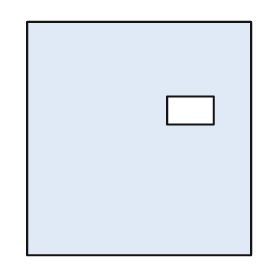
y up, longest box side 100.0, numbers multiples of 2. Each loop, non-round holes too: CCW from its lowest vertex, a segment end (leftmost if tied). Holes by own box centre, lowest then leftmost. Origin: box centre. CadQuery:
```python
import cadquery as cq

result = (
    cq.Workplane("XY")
    .moveTo(-48.0, -50.0)
    .lineTo(48.0, -50.0)
    .lineTo(48.0, 50.0)
    .lineTo(-48.0, 50.0)
    .close()
    .moveTo(12.0, 6.0)
    .lineTo(32.0, 6.0)
    .lineTo(32.0, 18.0)
    .lineTo(12.0, 18.0)
    .close()
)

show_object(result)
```